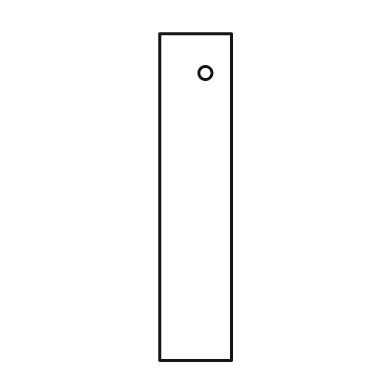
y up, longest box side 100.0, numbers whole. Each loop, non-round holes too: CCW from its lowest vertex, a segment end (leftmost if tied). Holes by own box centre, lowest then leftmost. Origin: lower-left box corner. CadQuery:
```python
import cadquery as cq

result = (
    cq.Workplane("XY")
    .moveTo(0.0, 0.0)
    .lineTo(22.0, 0.0)
    .lineTo(22.0, 100.0)
    .lineTo(0.0, 100.0)
    .close()
    .moveTo(14.0, 88.0)
    .circle(2.0)
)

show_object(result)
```